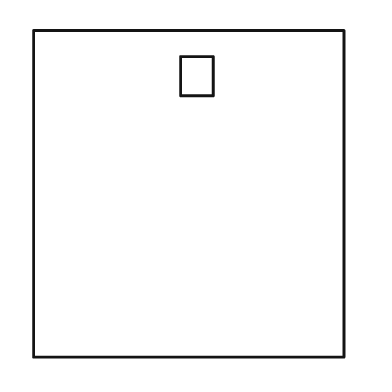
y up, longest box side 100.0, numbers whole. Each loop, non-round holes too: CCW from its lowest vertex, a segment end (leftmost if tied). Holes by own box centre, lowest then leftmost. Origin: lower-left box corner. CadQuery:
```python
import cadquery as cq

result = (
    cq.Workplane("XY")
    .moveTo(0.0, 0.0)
    .lineTo(95.0, 0.0)
    .lineTo(95.0, 100.0)
    .lineTo(0.0, 100.0)
    .close()
    .moveTo(45.0, 80.0)
    .lineTo(55.0, 80.0)
    .lineTo(55.0, 92.0)
    .lineTo(45.0, 92.0)
    .close()
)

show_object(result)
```